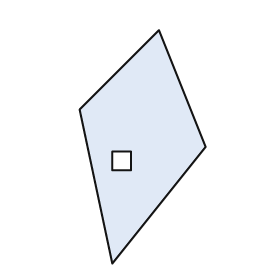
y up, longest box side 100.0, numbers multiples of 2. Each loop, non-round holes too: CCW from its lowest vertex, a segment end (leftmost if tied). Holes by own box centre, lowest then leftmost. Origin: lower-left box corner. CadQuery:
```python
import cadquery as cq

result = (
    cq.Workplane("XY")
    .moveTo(14.0, 0.0)
    .lineTo(54.0, 50.0)
    .lineTo(34.0, 100.0)
    .lineTo(0.0, 66.0)
    .close()
    .moveTo(14.0, 40.0)
    .lineTo(22.0, 40.0)
    .lineTo(22.0, 48.0)
    .lineTo(14.0, 48.0)
    .close()
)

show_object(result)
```